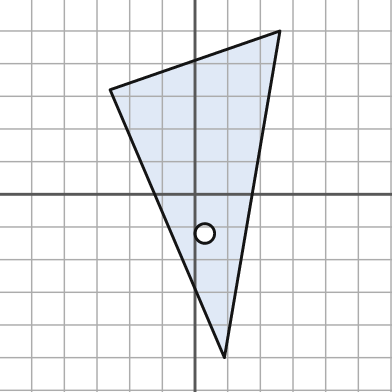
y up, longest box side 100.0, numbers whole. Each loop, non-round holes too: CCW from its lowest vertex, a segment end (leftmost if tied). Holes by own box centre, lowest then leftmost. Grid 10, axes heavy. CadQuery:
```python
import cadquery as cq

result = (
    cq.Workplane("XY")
    .moveTo(9.0, -50.0)
    .lineTo(26.0, 50.0)
    .lineTo(-26.0, 32.0)
    .close()
    .moveTo(3.0, -12.0)
    .circle(3.0)
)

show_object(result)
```